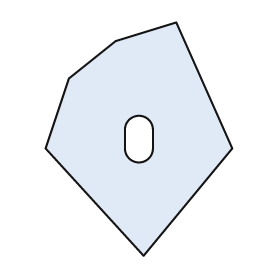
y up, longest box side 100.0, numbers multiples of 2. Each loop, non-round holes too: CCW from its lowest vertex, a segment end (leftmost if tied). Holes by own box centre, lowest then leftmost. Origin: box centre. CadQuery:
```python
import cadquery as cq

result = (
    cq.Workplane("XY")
    .moveTo(2.0, -50.0)
    .lineTo(40.0, -4.0)
    .lineTo(16.0, 50.0)
    .lineTo(-10.0, 42.0)
    .lineTo(-30.0, 26.0)
    .lineTo(-40.0, -4.0)
    .close()
    .moveTo(-6.0, -4.0)
    .threePointArc((0.0, -10.0), (6.0, -4.0))
    .lineTo(6.0, 4.0)
    .threePointArc((0.0, 10.0), (-6.0, 4.0))
    .close()
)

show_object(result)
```